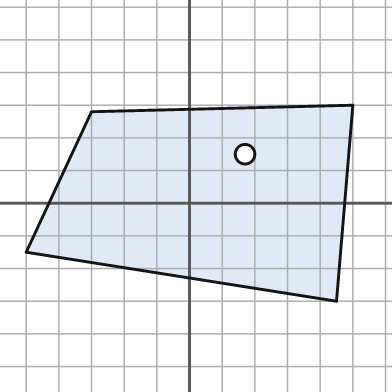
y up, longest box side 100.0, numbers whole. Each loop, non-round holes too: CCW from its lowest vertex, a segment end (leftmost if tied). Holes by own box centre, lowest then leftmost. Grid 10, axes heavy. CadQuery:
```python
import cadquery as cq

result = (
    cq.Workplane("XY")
    .moveTo(45.0, -30.0)
    .lineTo(50.0, 30.0)
    .lineTo(-30.0, 28.0)
    .lineTo(-50.0, -15.0)
    .close()
    .moveTo(17.0, 15.0)
    .circle(3.0)
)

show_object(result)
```